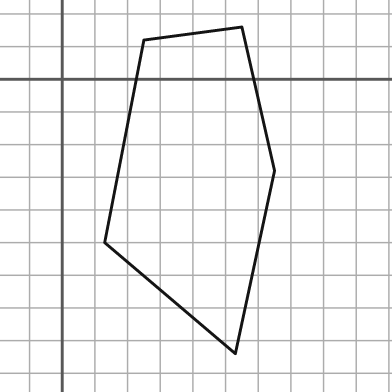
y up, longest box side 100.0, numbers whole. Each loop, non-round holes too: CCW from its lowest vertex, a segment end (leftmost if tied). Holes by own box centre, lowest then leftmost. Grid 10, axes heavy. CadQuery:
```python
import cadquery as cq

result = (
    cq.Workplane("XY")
    .moveTo(53.0, -84.0)
    .lineTo(65.0, -28.0)
    .lineTo(55.0, 16.0)
    .lineTo(25.0, 12.0)
    .lineTo(13.0, -50.0)
    .close()
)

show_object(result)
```